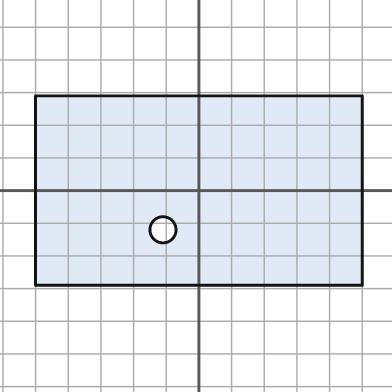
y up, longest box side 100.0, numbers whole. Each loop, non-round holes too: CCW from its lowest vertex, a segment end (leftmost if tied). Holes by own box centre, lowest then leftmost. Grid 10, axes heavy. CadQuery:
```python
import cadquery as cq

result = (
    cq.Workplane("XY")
    .moveTo(-50.0, -29.0)
    .lineTo(50.0, -29.0)
    .lineTo(50.0, 29.0)
    .lineTo(-50.0, 29.0)
    .close()
    .moveTo(-11.0, -12.0)
    .circle(4.0)
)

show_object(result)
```